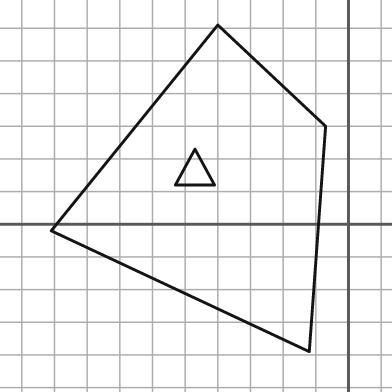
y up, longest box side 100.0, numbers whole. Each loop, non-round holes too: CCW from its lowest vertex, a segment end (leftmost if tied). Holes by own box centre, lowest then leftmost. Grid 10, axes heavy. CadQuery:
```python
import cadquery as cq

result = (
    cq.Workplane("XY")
    .moveTo(-12.0, -39.0)
    .lineTo(-7.0, 30.0)
    .lineTo(-40.0, 61.0)
    .lineTo(-91.0, -2.0)
    .close()
    .moveTo(-53.0, 12.0)
    .lineTo(-41.0, 12.0)
    .lineTo(-47.0, 23.0)
    .close()
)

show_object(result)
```